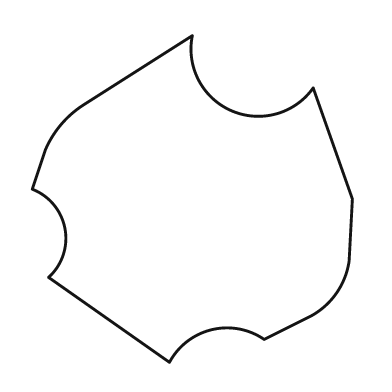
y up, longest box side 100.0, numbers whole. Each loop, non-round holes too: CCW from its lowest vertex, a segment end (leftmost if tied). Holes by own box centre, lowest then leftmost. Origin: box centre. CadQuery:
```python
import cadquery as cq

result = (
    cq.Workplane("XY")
    .moveTo(-7.0, -50.0)
    .threePointArc((6.0, -40.0), (22.0, -43.0))
    .lineTo(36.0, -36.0)
    .threePointArc((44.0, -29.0), (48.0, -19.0))
    .lineTo(49.0, 0.0)
    .lineTo(37.0, 34.0)
    .threePointArc((12.0, 27.0), (0.0, 50.0))
    .lineTo(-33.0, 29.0)
    .threePointArc((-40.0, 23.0), (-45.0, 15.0))
    .lineTo(-49.0, 3.0)
    .threePointArc((-39.0, -9.0), (-44.0, -24.0))
    .close()
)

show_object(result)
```